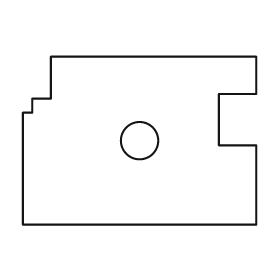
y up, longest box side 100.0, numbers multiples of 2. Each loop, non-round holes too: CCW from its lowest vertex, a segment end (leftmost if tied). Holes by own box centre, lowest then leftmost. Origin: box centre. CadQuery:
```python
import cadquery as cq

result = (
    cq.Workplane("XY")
    .moveTo(-50.0, -36.0)
    .lineTo(50.0, -36.0)
    .lineTo(50.0, -2.0)
    .lineTo(34.0, -2.0)
    .lineTo(34.0, 20.0)
    .lineTo(50.0, 20.0)
    .lineTo(50.0, 36.0)
    .lineTo(-38.0, 36.0)
    .lineTo(-38.0, 18.0)
    .lineTo(-46.0, 18.0)
    .lineTo(-46.0, 12.0)
    .lineTo(-50.0, 12.0)
    .close()
    .moveTo(0.0, 0.0)
    .circle(8.0)
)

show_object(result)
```